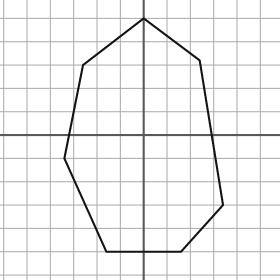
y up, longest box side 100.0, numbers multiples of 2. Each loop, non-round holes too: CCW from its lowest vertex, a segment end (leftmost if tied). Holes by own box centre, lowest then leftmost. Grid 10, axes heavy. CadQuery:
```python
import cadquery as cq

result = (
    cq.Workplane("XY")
    .moveTo(-16.0, -50.0)
    .lineTo(16.0, -50.0)
    .lineTo(34.0, -30.0)
    .lineTo(24.0, 32.0)
    .lineTo(0.0, 50.0)
    .lineTo(-26.0, 30.0)
    .lineTo(-34.0, -10.0)
    .close()
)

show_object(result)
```